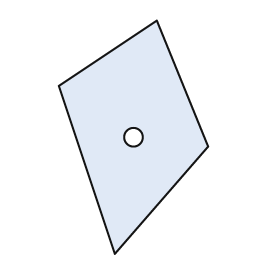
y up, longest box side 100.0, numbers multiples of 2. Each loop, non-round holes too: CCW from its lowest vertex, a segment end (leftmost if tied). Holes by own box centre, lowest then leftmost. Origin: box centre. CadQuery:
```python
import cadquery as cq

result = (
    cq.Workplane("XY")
    .moveTo(-8.0, -50.0)
    .lineTo(32.0, -4.0)
    .lineTo(10.0, 50.0)
    .lineTo(-32.0, 22.0)
    .close()
    .moveTo(0.0, 0.0)
    .circle(4.0)
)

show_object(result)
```